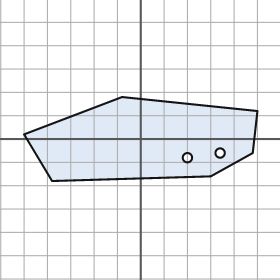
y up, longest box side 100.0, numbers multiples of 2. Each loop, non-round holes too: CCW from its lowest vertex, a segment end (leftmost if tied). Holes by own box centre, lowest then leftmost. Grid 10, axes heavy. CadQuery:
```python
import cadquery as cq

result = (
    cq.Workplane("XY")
    .moveTo(-38.0, -18.0)
    .lineTo(30.0, -16.0)
    .lineTo(48.0, -6.0)
    .lineTo(50.0, 12.0)
    .lineTo(-8.0, 18.0)
    .lineTo(-50.0, 2.0)
    .close()
    .moveTo(20.0, -8.0)
    .circle(2.0)
    .moveTo(34.0, -6.0)
    .circle(2.0)
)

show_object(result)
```